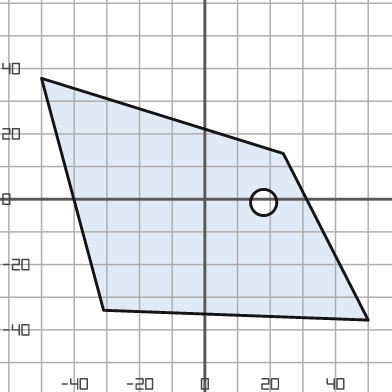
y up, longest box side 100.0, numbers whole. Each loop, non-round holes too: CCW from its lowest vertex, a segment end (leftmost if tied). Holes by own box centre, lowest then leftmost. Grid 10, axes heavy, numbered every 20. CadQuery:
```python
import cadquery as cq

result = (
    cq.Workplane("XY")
    .moveTo(50.0, -37.0)
    .lineTo(24.0, 14.0)
    .lineTo(-50.0, 37.0)
    .lineTo(-31.0, -34.0)
    .close()
    .moveTo(18.0, -1.0)
    .circle(4.0)
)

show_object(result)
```